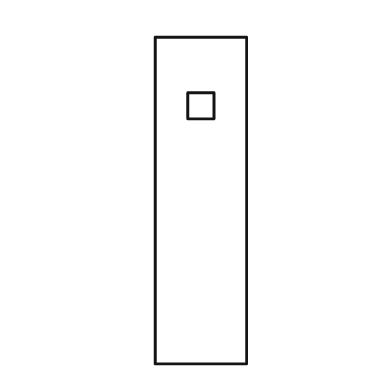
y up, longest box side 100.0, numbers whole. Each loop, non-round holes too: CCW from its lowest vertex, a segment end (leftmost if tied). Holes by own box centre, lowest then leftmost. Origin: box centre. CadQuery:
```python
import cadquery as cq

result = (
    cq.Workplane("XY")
    .moveTo(-14.0, -50.0)
    .lineTo(14.0, -50.0)
    .lineTo(14.0, 50.0)
    .lineTo(-14.0, 50.0)
    .close()
    .moveTo(-4.0, 25.0)
    .lineTo(4.0, 25.0)
    .lineTo(4.0, 33.0)
    .lineTo(-4.0, 33.0)
    .close()
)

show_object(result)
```